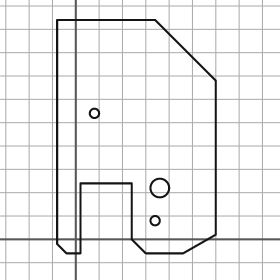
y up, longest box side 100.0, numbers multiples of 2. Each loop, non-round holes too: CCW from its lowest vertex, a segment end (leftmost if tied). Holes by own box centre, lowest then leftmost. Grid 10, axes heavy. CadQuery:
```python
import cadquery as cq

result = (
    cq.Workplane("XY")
    .moveTo(-4.0, -6.0)
    .lineTo(2.0, -6.0)
    .lineTo(2.0, 24.0)
    .lineTo(24.0, 24.0)
    .lineTo(24.0, 0.0)
    .lineTo(30.0, -6.0)
    .lineTo(46.0, -6.0)
    .lineTo(60.0, 2.0)
    .lineTo(60.0, 68.0)
    .lineTo(34.0, 94.0)
    .lineTo(-8.0, 94.0)
    .lineTo(-8.0, -2.0)
    .close()
    .moveTo(34.0, 8.0)
    .circle(2.0)
    .moveTo(36.0, 22.0)
    .circle(4.0)
    .moveTo(8.0, 54.0)
    .circle(2.0)
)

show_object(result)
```